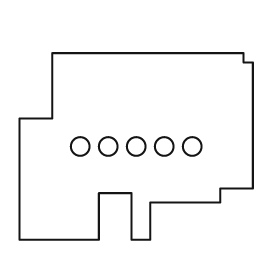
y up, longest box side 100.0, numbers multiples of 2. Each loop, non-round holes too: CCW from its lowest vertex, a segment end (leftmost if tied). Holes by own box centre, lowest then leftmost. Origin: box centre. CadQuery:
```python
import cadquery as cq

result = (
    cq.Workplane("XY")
    .moveTo(-50.0, -40.0)
    .lineTo(-16.0, -40.0)
    .lineTo(-16.0, -20.0)
    .lineTo(-2.0, -20.0)
    .lineTo(-2.0, -40.0)
    .lineTo(6.0, -40.0)
    .lineTo(6.0, -24.0)
    .lineTo(36.0, -24.0)
    .lineTo(36.0, -18.0)
    .lineTo(50.0, -18.0)
    .lineTo(50.0, 36.0)
    .lineTo(46.0, 36.0)
    .lineTo(46.0, 40.0)
    .lineTo(-36.0, 40.0)
    .lineTo(-36.0, 12.0)
    .lineTo(-50.0, 12.0)
    .close()
    .moveTo(-24.0, 0.0)
    .circle(4.0)
    .moveTo(-12.0, 0.0)
    .circle(4.0)
    .moveTo(0.0, 0.0)
    .circle(4.0)
    .moveTo(12.0, 0.0)
    .circle(4.0)
    .moveTo(24.0, 0.0)
    .circle(4.0)
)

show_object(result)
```